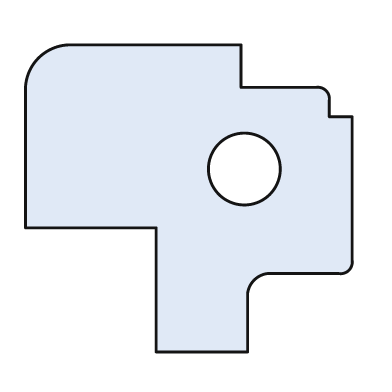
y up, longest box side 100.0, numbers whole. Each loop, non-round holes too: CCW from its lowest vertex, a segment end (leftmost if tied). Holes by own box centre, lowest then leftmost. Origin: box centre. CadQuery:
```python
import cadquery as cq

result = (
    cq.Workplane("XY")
    .moveTo(-10.0, -47.0)
    .lineTo(18.0, -47.0)
    .lineTo(18.0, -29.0)
    .threePointArc((20.0, -25.0), (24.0, -23.0))
    .lineTo(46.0, -23.0)
    .threePointArc((49.0, -22.0), (50.0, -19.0))
    .lineTo(50.0, 25.0)
    .lineTo(43.0, 25.0)
    .lineTo(43.0, 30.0)
    .threePointArc((42.0, 33.0), (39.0, 34.0))
    .lineTo(16.0, 34.0)
    .lineTo(16.0, 47.0)
    .lineTo(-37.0, 47.0)
    .threePointArc((-46.0, 43.0), (-50.0, 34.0))
    .lineTo(-50.0, -9.0)
    .lineTo(-10.0, -9.0)
    .close()
    .moveTo(17.0, 9.0)
    .circle(11.0)
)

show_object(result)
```